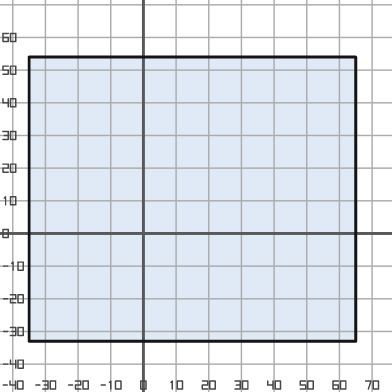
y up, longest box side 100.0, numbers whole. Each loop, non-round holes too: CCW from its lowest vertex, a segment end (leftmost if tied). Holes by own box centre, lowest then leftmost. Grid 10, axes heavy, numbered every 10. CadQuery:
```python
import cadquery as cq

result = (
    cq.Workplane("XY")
    .moveTo(-35.0, -33.0)
    .lineTo(65.0, -33.0)
    .lineTo(65.0, 54.0)
    .lineTo(-35.0, 54.0)
    .close()
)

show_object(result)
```